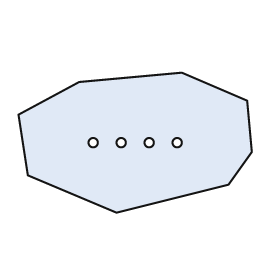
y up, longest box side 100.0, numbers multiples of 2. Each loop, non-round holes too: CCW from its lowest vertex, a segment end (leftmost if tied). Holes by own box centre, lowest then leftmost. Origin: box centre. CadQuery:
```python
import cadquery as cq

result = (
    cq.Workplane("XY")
    .moveTo(-8.0, -30.0)
    .lineTo(40.0, -18.0)
    .lineTo(50.0, -4.0)
    .lineTo(48.0, 18.0)
    .lineTo(20.0, 30.0)
    .lineTo(-24.0, 26.0)
    .lineTo(-50.0, 12.0)
    .lineTo(-46.0, -14.0)
    .close()
    .moveTo(-18.0, 0.0)
    .circle(2.0)
    .moveTo(-6.0, 0.0)
    .circle(2.0)
    .moveTo(6.0, 0.0)
    .circle(2.0)
    .moveTo(18.0, 0.0)
    .circle(2.0)
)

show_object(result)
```